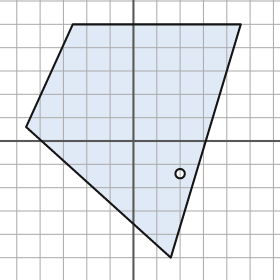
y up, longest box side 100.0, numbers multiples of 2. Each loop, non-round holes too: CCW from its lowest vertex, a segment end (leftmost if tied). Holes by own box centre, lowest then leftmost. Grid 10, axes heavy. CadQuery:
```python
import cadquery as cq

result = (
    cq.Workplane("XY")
    .moveTo(16.0, -50.0)
    .lineTo(46.0, 50.0)
    .lineTo(-26.0, 50.0)
    .lineTo(-46.0, 6.0)
    .close()
    .moveTo(20.0, -14.0)
    .circle(2.0)
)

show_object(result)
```